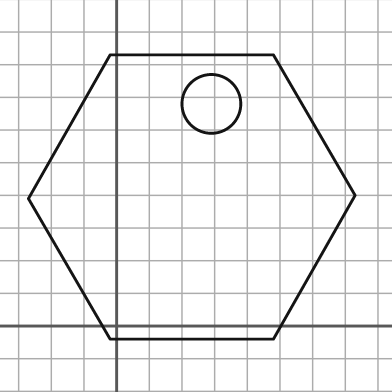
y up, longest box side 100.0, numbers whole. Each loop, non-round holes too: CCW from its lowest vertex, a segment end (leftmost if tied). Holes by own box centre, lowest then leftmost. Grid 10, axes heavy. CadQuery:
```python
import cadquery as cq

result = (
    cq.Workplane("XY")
    .moveTo(-2.0, -4.0)
    .lineTo(48.0, -4.0)
    .lineTo(73.0, 40.0)
    .lineTo(48.0, 83.0)
    .lineTo(-2.0, 83.0)
    .lineTo(-27.0, 39.0)
    .close()
    .moveTo(29.0, 68.0)
    .circle(9.0)
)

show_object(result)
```